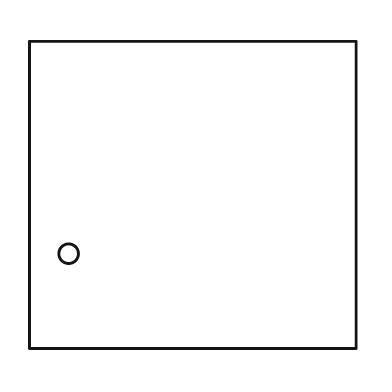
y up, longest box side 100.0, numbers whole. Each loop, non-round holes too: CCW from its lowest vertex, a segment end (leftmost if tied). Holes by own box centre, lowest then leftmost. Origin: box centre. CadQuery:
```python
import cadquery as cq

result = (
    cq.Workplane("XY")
    .moveTo(-50.0, -47.0)
    .lineTo(50.0, -47.0)
    .lineTo(50.0, 47.0)
    .lineTo(-50.0, 47.0)
    .close()
    .moveTo(-38.0, -18.0)
    .circle(3.0)
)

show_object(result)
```